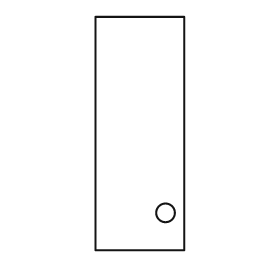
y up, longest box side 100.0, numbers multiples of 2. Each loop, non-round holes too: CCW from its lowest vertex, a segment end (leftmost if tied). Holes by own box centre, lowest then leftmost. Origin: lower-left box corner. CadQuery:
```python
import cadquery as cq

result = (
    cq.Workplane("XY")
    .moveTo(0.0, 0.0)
    .lineTo(38.0, 0.0)
    .lineTo(38.0, 100.0)
    .lineTo(0.0, 100.0)
    .close()
    .moveTo(30.0, 16.0)
    .circle(4.0)
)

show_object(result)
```